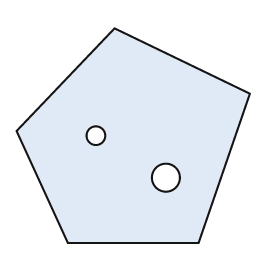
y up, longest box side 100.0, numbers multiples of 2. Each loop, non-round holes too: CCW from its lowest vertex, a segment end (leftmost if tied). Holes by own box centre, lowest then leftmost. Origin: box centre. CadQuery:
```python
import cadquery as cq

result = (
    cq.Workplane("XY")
    .moveTo(-28.0, -46.0)
    .lineTo(28.0, -46.0)
    .lineTo(50.0, 18.0)
    .lineTo(-8.0, 46.0)
    .lineTo(-50.0, 2.0)
    .close()
    .moveTo(14.0, -18.0)
    .circle(6.0)
    .moveTo(-16.0, 0.0)
    .circle(4.0)
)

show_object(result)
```